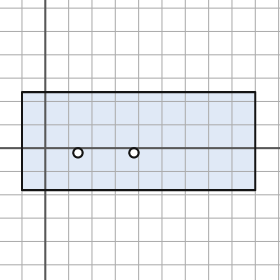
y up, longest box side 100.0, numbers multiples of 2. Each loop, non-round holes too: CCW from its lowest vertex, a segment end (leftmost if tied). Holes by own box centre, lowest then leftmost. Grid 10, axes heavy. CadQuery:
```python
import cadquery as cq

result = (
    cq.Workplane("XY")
    .moveTo(-10.0, -18.0)
    .lineTo(90.0, -18.0)
    .lineTo(90.0, 24.0)
    .lineTo(-10.0, 24.0)
    .close()
    .moveTo(14.0, -2.0)
    .circle(2.0)
    .moveTo(38.0, -2.0)
    .circle(2.0)
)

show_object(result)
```